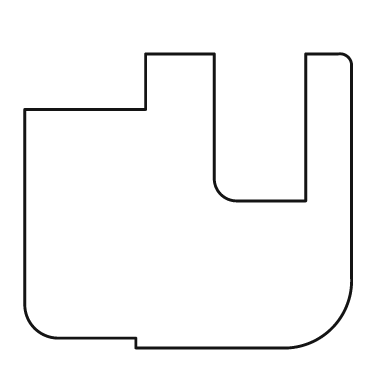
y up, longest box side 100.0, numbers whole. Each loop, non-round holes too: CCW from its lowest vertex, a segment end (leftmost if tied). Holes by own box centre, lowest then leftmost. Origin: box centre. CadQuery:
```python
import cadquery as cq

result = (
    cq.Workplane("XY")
    .moveTo(-16.0, -45.0)
    .lineTo(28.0, -45.0)
    .threePointArc((44.0, -39.0), (50.0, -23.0))
    .lineTo(50.0, 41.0)
    .threePointArc((49.0, 44.0), (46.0, 45.0))
    .lineTo(36.0, 45.0)
    .lineTo(36.0, 0.0)
    .lineTo(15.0, 0.0)
    .threePointArc((10.0, 2.0), (8.0, 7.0))
    .lineTo(8.0, 45.0)
    .lineTo(-13.0, 45.0)
    .lineTo(-13.0, 28.0)
    .lineTo(-50.0, 28.0)
    .lineTo(-50.0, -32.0)
    .threePointArc((-47.0, -39.0), (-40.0, -42.0))
    .lineTo(-16.0, -42.0)
    .close()
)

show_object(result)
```